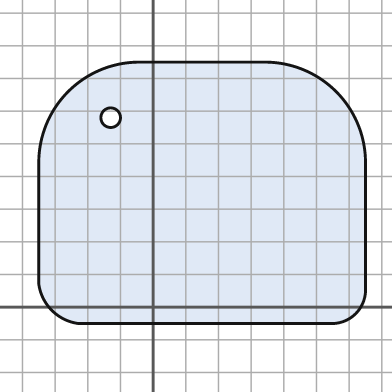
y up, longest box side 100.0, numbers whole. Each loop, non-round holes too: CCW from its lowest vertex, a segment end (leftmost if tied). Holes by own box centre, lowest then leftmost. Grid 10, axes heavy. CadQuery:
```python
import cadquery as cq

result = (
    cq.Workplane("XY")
    .moveTo(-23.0, -5.0)
    .lineTo(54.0, -5.0)
    .threePointArc((62.0, -2.0), (65.0, 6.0))
    .lineTo(65.0, 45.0)
    .threePointArc((56.0, 66.0), (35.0, 75.0))
    .lineTo(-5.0, 75.0)
    .threePointArc((-26.0, 66.0), (-35.0, 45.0))
    .lineTo(-35.0, 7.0)
    .threePointArc((-31.0, -1.0), (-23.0, -5.0))
    .close()
    .moveTo(-13.0, 58.0)
    .circle(3.0)
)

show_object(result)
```